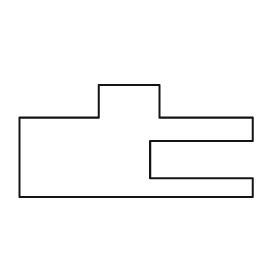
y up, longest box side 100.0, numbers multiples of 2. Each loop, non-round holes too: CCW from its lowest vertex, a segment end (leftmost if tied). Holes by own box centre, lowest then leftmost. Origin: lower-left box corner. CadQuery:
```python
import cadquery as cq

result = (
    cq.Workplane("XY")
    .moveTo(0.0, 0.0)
    .lineTo(100.0, 0.0)
    .lineTo(100.0, 8.0)
    .lineTo(56.0, 8.0)
    .lineTo(56.0, 24.0)
    .lineTo(100.0, 24.0)
    .lineTo(100.0, 34.0)
    .lineTo(60.0, 34.0)
    .lineTo(60.0, 48.0)
    .lineTo(34.0, 48.0)
    .lineTo(34.0, 34.0)
    .lineTo(0.0, 34.0)
    .close()
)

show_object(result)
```